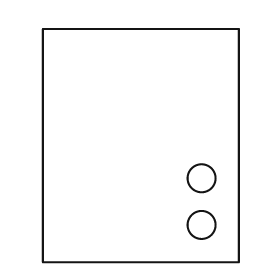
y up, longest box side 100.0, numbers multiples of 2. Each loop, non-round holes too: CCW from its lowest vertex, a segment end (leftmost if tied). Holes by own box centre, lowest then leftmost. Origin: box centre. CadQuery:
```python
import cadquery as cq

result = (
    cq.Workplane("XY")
    .moveTo(-42.0, -50.0)
    .lineTo(42.0, -50.0)
    .lineTo(42.0, 50.0)
    .lineTo(-42.0, 50.0)
    .close()
    .moveTo(26.0, -34.0)
    .circle(6.0)
    .moveTo(26.0, -14.0)
    .circle(6.0)
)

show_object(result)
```